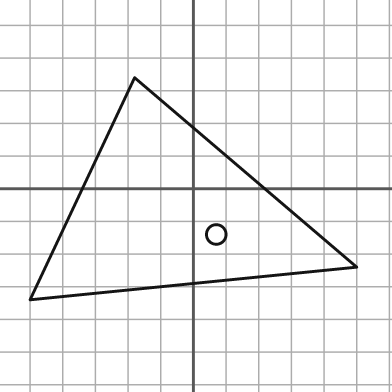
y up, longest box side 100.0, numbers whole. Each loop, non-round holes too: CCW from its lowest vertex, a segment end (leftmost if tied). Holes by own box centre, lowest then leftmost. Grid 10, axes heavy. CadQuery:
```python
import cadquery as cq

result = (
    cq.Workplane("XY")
    .moveTo(-50.0, -34.0)
    .lineTo(50.0, -24.0)
    .lineTo(-18.0, 34.0)
    .close()
    .moveTo(7.0, -14.0)
    .circle(3.0)
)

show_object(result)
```